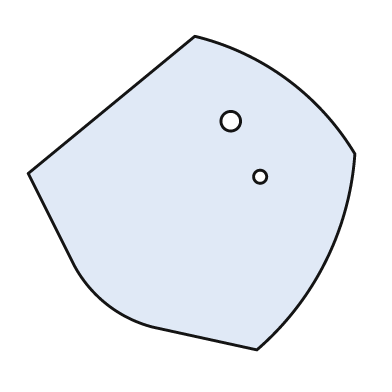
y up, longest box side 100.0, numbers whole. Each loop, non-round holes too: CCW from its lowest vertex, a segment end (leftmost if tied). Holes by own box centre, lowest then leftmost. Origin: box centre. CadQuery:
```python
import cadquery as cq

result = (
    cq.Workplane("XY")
    .moveTo(20.0, -48.0)
    .threePointArc((41.0, -21.0), (50.0, 12.0))
    .threePointArc((29.0, 35.0), (1.0, 48.0))
    .lineTo(-50.0, 6.0)
    .lineTo(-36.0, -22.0)
    .threePointArc((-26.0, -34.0), (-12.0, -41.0))
    .close()
    .moveTo(21.0, 5.0)
    .circle(2.0)
    .moveTo(12.0, 22.0)
    .circle(3.0)
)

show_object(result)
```